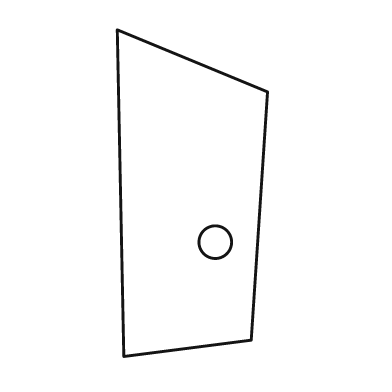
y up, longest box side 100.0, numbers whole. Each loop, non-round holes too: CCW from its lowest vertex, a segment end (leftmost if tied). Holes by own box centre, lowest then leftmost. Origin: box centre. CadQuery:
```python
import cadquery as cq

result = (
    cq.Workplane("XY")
    .moveTo(-21.0, -50.0)
    .lineTo(18.0, -45.0)
    .lineTo(23.0, 31.0)
    .lineTo(-23.0, 50.0)
    .close()
    .moveTo(7.0, -15.0)
    .circle(5.0)
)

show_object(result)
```